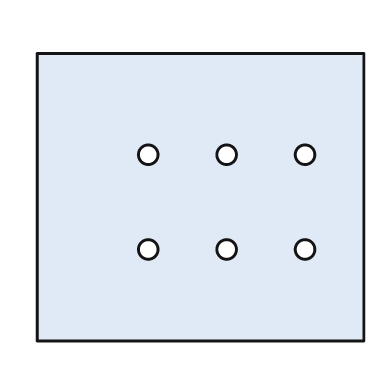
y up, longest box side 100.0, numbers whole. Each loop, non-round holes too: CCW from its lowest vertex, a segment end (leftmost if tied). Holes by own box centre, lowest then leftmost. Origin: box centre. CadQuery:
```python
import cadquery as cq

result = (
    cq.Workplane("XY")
    .moveTo(-50.0, -44.0)
    .lineTo(50.0, -44.0)
    .lineTo(50.0, 44.0)
    .lineTo(-50.0, 44.0)
    .close()
    .moveTo(-16.0, -16.0)
    .circle(3.0)
    .moveTo(8.0, -16.0)
    .circle(3.0)
    .moveTo(32.0, -16.0)
    .circle(3.0)
    .moveTo(-16.0, 13.0)
    .circle(3.0)
    .moveTo(8.0, 13.0)
    .circle(3.0)
    .moveTo(32.0, 13.0)
    .circle(3.0)
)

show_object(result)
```